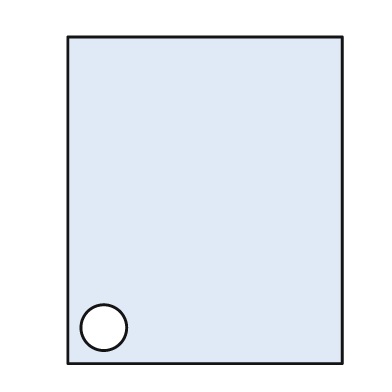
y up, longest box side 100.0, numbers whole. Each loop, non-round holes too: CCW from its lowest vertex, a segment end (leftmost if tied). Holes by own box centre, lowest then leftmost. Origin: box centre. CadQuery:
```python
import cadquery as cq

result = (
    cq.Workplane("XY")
    .moveTo(-42.0, -50.0)
    .lineTo(42.0, -50.0)
    .lineTo(42.0, 50.0)
    .lineTo(-42.0, 50.0)
    .close()
    .moveTo(-31.0, -39.0)
    .circle(7.0)
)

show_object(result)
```